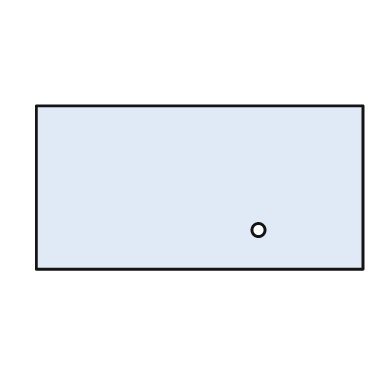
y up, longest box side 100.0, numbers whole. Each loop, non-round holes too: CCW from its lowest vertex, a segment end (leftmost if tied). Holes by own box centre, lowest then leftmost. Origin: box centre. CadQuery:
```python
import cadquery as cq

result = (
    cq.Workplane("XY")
    .moveTo(-50.0, -25.0)
    .lineTo(50.0, -25.0)
    .lineTo(50.0, 25.0)
    .lineTo(-50.0, 25.0)
    .close()
    .moveTo(18.0, -13.0)
    .circle(2.0)
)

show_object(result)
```